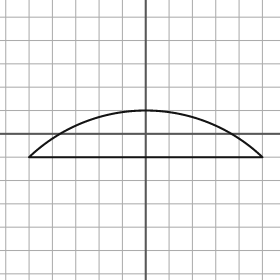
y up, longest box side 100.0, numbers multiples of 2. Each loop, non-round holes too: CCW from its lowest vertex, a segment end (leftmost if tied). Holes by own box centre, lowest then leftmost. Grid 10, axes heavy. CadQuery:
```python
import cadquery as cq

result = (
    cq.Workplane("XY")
    .moveTo(-50.0, -10.0)
    .lineTo(50.0, -10.0)
    .threePointArc((0.0, 10.0), (-50.0, -10.0))
    .close()
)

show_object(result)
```